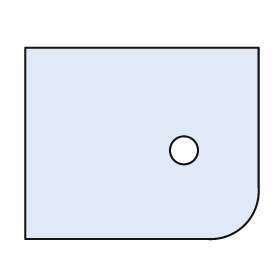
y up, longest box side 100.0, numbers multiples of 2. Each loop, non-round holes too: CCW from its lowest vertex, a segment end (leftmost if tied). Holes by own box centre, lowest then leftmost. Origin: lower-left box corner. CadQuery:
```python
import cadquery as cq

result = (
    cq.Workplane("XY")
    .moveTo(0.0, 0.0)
    .lineTo(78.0, 0.0)
    .threePointArc((94.0, 6.0), (100.0, 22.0))
    .lineTo(100.0, 82.0)
    .lineTo(0.0, 82.0)
    .close()
    .moveTo(68.0, 38.0)
    .circle(6.0)
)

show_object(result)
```